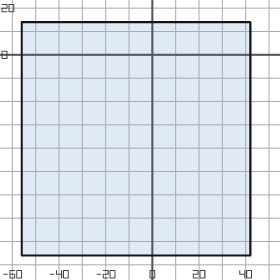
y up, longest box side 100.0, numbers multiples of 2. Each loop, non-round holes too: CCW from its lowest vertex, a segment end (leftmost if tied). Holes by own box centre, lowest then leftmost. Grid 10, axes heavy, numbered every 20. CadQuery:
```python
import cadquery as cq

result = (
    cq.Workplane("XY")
    .moveTo(-56.0, -86.0)
    .lineTo(42.0, -86.0)
    .lineTo(42.0, 14.0)
    .lineTo(-56.0, 14.0)
    .close()
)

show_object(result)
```